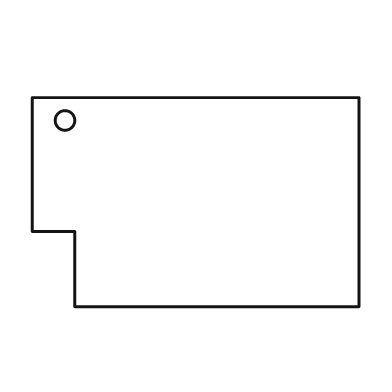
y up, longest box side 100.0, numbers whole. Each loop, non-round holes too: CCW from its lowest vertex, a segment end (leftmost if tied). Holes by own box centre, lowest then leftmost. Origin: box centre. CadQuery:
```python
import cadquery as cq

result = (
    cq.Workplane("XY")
    .moveTo(-37.0, -32.0)
    .lineTo(50.0, -32.0)
    .lineTo(50.0, 32.0)
    .lineTo(-50.0, 32.0)
    .lineTo(-50.0, -9.0)
    .lineTo(-37.0, -9.0)
    .close()
    .moveTo(-40.0, 25.0)
    .circle(3.0)
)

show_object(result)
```